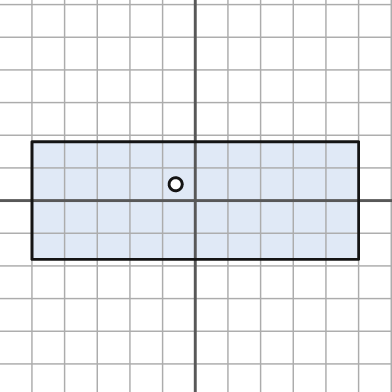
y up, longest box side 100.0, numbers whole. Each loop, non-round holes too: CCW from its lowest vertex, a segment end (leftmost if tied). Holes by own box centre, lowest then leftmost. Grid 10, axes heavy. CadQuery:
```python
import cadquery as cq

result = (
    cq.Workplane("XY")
    .moveTo(-50.0, -18.0)
    .lineTo(50.0, -18.0)
    .lineTo(50.0, 18.0)
    .lineTo(-50.0, 18.0)
    .close()
    .moveTo(-6.0, 5.0)
    .circle(2.0)
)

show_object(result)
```